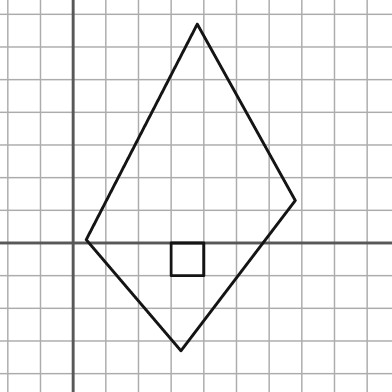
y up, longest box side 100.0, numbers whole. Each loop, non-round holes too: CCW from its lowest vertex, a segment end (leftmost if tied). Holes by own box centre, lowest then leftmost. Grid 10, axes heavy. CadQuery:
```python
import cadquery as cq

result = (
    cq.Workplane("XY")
    .moveTo(33.0, -33.0)
    .lineTo(68.0, 13.0)
    .lineTo(38.0, 67.0)
    .lineTo(4.0, 1.0)
    .close()
    .moveTo(30.0, -10.0)
    .lineTo(40.0, -10.0)
    .lineTo(40.0, 0.0)
    .lineTo(30.0, 0.0)
    .close()
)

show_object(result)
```